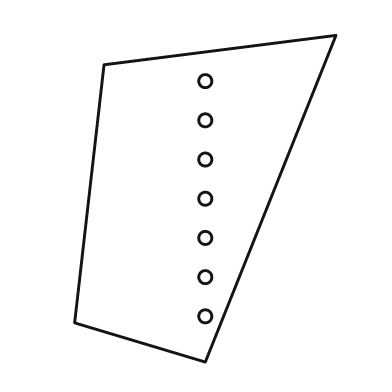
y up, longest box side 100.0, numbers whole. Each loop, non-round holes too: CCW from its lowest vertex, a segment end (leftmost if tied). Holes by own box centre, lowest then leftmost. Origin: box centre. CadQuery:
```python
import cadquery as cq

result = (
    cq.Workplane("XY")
    .moveTo(0.0, -50.0)
    .lineTo(40.0, 50.0)
    .lineTo(-31.0, 41.0)
    .lineTo(-40.0, -38.0)
    .close()
    .moveTo(0.0, -36.0)
    .circle(2.0)
    .moveTo(0.0, -24.0)
    .circle(2.0)
    .moveTo(0.0, -12.0)
    .circle(2.0)
    .moveTo(0.0, 0.0)
    .circle(2.0)
    .moveTo(0.0, 12.0)
    .circle(2.0)
    .moveTo(0.0, 24.0)
    .circle(2.0)
    .moveTo(0.0, 36.0)
    .circle(2.0)
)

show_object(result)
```